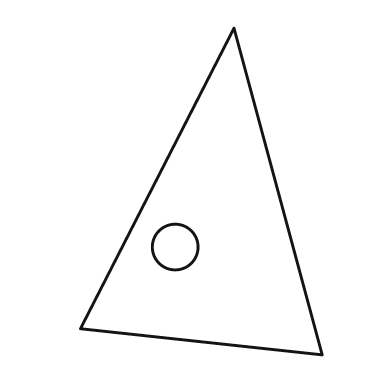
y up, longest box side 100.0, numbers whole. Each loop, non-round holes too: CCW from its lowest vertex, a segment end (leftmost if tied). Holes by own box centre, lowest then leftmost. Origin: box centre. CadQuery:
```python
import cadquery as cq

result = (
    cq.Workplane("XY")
    .moveTo(37.0, -50.0)
    .lineTo(10.0, 50.0)
    .lineTo(-37.0, -42.0)
    .close()
    .moveTo(-8.0, -17.0)
    .circle(7.0)
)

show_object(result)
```